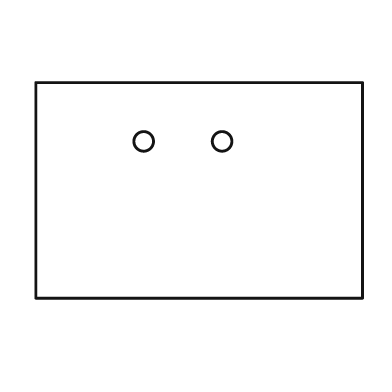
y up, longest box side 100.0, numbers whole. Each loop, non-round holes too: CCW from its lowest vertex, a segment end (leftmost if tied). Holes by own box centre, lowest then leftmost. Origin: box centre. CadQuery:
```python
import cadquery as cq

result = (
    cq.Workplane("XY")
    .moveTo(-50.0, -33.0)
    .lineTo(50.0, -33.0)
    .lineTo(50.0, 33.0)
    .lineTo(-50.0, 33.0)
    .close()
    .moveTo(-17.0, 15.0)
    .circle(3.0)
    .moveTo(7.0, 15.0)
    .circle(3.0)
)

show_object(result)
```